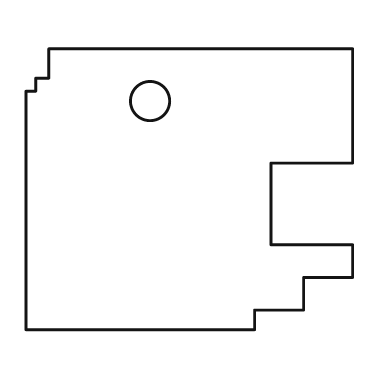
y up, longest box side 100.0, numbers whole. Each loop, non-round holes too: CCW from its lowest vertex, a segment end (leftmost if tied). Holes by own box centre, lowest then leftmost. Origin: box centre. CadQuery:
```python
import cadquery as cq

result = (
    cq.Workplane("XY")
    .moveTo(-50.0, -43.0)
    .lineTo(20.0, -43.0)
    .lineTo(20.0, -37.0)
    .lineTo(35.0, -37.0)
    .lineTo(35.0, -27.0)
    .lineTo(50.0, -27.0)
    .lineTo(50.0, -17.0)
    .lineTo(25.0, -17.0)
    .lineTo(25.0, 8.0)
    .lineTo(50.0, 8.0)
    .lineTo(50.0, 43.0)
    .lineTo(-43.0, 43.0)
    .lineTo(-43.0, 34.0)
    .lineTo(-47.0, 34.0)
    .lineTo(-47.0, 30.0)
    .lineTo(-50.0, 30.0)
    .close()
    .moveTo(-12.0, 27.0)
    .circle(6.0)
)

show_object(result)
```